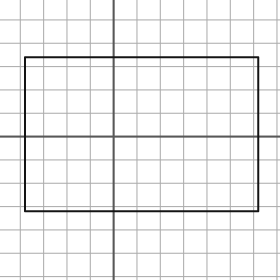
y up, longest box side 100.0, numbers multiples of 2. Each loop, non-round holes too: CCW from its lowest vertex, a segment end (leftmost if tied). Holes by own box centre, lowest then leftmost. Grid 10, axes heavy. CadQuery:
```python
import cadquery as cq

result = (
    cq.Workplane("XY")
    .moveTo(-38.0, -32.0)
    .lineTo(62.0, -32.0)
    .lineTo(62.0, 34.0)
    .lineTo(-38.0, 34.0)
    .close()
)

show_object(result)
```